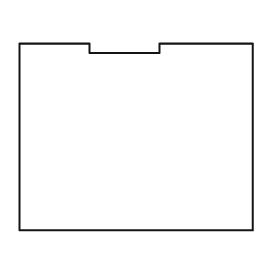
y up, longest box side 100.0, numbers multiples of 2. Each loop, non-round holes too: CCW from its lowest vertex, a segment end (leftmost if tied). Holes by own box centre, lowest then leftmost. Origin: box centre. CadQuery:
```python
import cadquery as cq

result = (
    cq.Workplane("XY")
    .moveTo(-50.0, -40.0)
    .lineTo(50.0, -40.0)
    .lineTo(50.0, 40.0)
    .lineTo(10.0, 40.0)
    .lineTo(10.0, 36.0)
    .lineTo(-20.0, 36.0)
    .lineTo(-20.0, 40.0)
    .lineTo(-50.0, 40.0)
    .close()
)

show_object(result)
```